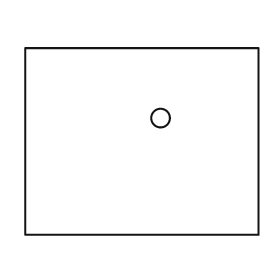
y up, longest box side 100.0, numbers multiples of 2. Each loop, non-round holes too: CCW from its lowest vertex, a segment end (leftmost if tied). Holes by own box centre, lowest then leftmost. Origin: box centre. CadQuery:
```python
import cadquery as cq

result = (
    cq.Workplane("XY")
    .moveTo(-50.0, -40.0)
    .lineTo(50.0, -40.0)
    .lineTo(50.0, 40.0)
    .lineTo(-50.0, 40.0)
    .close()
    .moveTo(8.0, 10.0)
    .circle(4.0)
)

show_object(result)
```